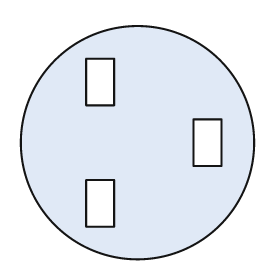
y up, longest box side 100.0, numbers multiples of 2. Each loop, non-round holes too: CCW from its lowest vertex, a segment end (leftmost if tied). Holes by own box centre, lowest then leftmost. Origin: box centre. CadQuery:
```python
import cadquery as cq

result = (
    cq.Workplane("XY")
    .moveTo(0.0, 0.0)
    .circle(50.0)
    .moveTo(-22.0, -36.0)
    .lineTo(-10.0, -36.0)
    .lineTo(-10.0, -16.0)
    .lineTo(-22.0, -16.0)
    .close()
    .moveTo(24.0, -10.0)
    .lineTo(36.0, -10.0)
    .lineTo(36.0, 10.0)
    .lineTo(24.0, 10.0)
    .close()
    .moveTo(-22.0, 16.0)
    .lineTo(-10.0, 16.0)
    .lineTo(-10.0, 36.0)
    .lineTo(-22.0, 36.0)
    .close()
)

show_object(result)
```